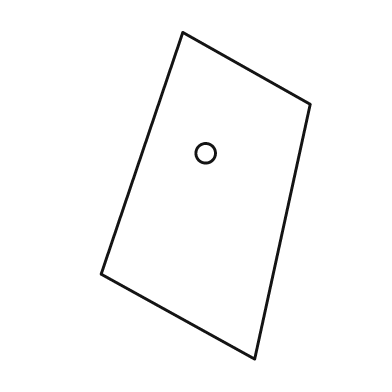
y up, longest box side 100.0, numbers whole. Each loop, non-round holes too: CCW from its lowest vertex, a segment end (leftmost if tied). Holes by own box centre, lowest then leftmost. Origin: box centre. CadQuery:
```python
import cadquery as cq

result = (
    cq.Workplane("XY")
    .moveTo(15.0, -50.0)
    .lineTo(32.0, 28.0)
    .lineTo(-7.0, 50.0)
    .lineTo(-32.0, -24.0)
    .close()
    .moveTo(0.0, 13.0)
    .circle(3.0)
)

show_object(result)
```